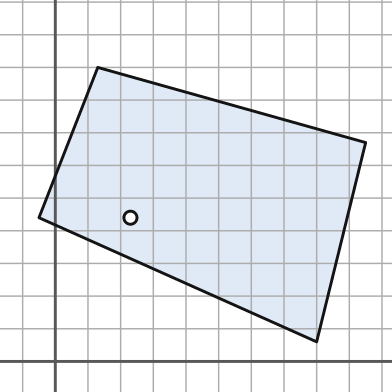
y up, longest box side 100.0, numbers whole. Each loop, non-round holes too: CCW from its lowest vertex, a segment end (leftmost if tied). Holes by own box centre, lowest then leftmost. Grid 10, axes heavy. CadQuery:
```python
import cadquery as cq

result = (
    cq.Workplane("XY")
    .moveTo(80.0, 6.0)
    .lineTo(95.0, 67.0)
    .lineTo(13.0, 90.0)
    .lineTo(-5.0, 44.0)
    .close()
    .moveTo(23.0, 44.0)
    .circle(2.0)
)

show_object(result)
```